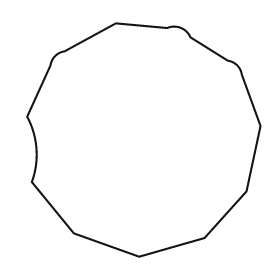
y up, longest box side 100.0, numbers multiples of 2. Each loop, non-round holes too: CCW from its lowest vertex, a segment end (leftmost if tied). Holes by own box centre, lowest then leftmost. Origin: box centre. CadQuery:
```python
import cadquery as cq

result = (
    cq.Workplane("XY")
    .moveTo(-2.0, -50.0)
    .lineTo(26.0, -42.0)
    .lineTo(44.0, -22.0)
    .lineTo(50.0, 6.0)
    .lineTo(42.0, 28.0)
    .threePointArc((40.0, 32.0), (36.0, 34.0))
    .lineTo(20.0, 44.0)
    .threePointArc((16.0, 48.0), (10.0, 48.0))
    .lineTo(-12.0, 50.0)
    .lineTo(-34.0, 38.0)
    .threePointArc((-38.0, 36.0), (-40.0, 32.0))
    .lineTo(-50.0, 10.0)
    .threePointArc((-46.0, -4.0), (-48.0, -18.0))
    .lineTo(-30.0, -40.0)
    .close()
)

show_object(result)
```